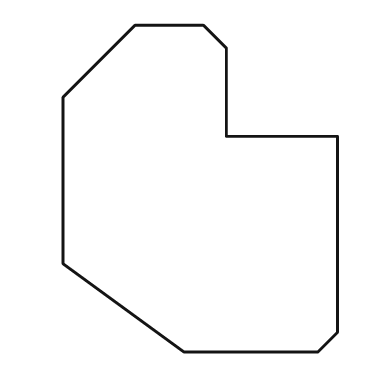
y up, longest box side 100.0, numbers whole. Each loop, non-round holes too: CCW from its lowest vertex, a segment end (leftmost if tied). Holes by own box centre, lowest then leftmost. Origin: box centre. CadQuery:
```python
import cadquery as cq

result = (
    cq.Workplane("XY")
    .moveTo(-5.0, -50.0)
    .lineTo(36.0, -50.0)
    .lineTo(42.0, -44.0)
    .lineTo(42.0, 16.0)
    .lineTo(8.0, 16.0)
    .lineTo(8.0, 43.0)
    .lineTo(1.0, 50.0)
    .lineTo(-20.0, 50.0)
    .lineTo(-42.0, 28.0)
    .lineTo(-42.0, -23.0)
    .close()
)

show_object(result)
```